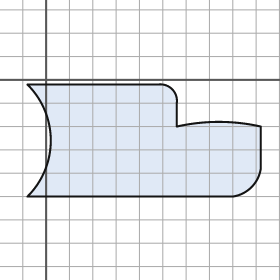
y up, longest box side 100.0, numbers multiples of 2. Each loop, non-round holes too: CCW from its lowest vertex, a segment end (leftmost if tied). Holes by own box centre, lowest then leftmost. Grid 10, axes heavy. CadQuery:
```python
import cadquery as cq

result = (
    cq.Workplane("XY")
    .moveTo(-8.0, -50.0)
    .lineTo(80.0, -50.0)
    .threePointArc((88.0, -46.0), (92.0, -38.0))
    .lineTo(92.0, -20.0)
    .threePointArc((74.0, -18.0), (56.0, -20.0))
    .lineTo(56.0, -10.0)
    .threePointArc((54.0, -4.0), (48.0, -2.0))
    .lineTo(-8.0, -2.0)
    .threePointArc((2.0, -26.0), (-8.0, -50.0))
    .close()
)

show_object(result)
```